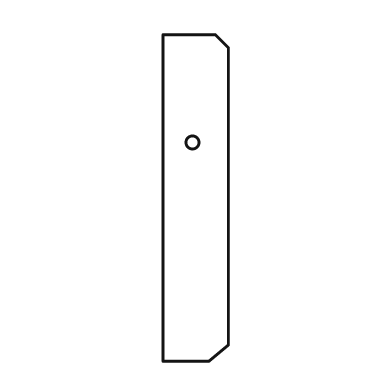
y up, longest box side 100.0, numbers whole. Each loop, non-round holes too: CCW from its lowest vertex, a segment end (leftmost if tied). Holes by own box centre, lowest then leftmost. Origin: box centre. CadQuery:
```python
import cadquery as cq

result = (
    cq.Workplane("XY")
    .moveTo(-10.0, -50.0)
    .lineTo(4.0, -50.0)
    .lineTo(10.0, -45.0)
    .lineTo(10.0, 46.0)
    .lineTo(6.0, 50.0)
    .lineTo(-10.0, 50.0)
    .close()
    .moveTo(-1.0, 17.0)
    .circle(2.0)
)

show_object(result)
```